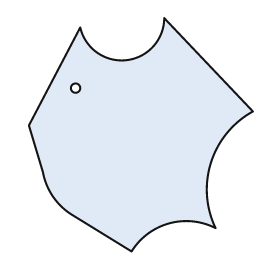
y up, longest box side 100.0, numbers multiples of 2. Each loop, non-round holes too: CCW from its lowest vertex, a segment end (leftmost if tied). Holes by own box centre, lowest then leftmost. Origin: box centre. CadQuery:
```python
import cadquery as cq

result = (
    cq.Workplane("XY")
    .moveTo(-4.0, -50.0)
    .threePointArc((12.0, -38.0), (32.0, -40.0))
    .threePointArc((30.0, -12.0), (48.0, 10.0))
    .lineTo(10.0, 50.0)
    .threePointArc((-6.0, 32.0), (-26.0, 46.0))
    .lineTo(-48.0, 4.0)
    .lineTo(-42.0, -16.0)
    .threePointArc((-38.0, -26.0), (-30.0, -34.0))
    .close()
    .moveTo(-28.0, 20.0)
    .circle(2.0)
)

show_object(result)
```